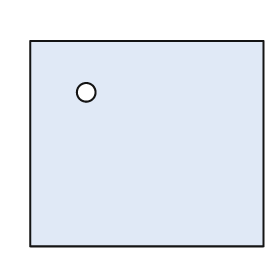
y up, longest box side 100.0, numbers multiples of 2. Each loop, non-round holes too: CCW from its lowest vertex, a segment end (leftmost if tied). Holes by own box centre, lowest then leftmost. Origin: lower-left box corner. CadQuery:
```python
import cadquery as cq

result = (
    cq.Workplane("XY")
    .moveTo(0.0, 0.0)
    .lineTo(100.0, 0.0)
    .lineTo(100.0, 88.0)
    .lineTo(0.0, 88.0)
    .close()
    .moveTo(24.0, 66.0)
    .circle(4.0)
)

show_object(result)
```